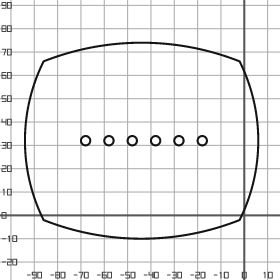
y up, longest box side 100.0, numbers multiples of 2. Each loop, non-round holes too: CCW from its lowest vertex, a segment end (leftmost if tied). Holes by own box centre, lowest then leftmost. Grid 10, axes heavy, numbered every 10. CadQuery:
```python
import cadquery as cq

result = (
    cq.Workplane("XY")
    .moveTo(-86.0, -2.0)
    .threePointArc((-44.0, -10.0), (-2.0, -2.0))
    .threePointArc((6.0, 32.0), (-2.0, 66.0))
    .threePointArc((-44.0, 74.0), (-86.0, 66.0))
    .threePointArc((-94.0, 32.0), (-86.0, -2.0))
    .close()
    .moveTo(-68.0, 32.0)
    .circle(2.0)
    .moveTo(-58.0, 32.0)
    .circle(2.0)
    .moveTo(-48.0, 32.0)
    .circle(2.0)
    .moveTo(-38.0, 32.0)
    .circle(2.0)
    .moveTo(-28.0, 32.0)
    .circle(2.0)
    .moveTo(-18.0, 32.0)
    .circle(2.0)
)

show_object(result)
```